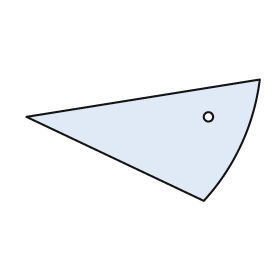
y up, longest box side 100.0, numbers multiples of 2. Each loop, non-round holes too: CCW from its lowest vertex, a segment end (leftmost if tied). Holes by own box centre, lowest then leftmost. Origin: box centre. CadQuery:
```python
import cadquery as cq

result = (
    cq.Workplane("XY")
    .moveTo(26.0, -26.0)
    .threePointArc((42.0, -2.0), (50.0, 26.0))
    .lineTo(-50.0, 10.0)
    .close()
    .moveTo(28.0, 10.0)
    .circle(2.0)
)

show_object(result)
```